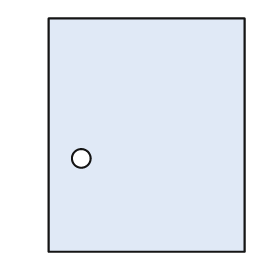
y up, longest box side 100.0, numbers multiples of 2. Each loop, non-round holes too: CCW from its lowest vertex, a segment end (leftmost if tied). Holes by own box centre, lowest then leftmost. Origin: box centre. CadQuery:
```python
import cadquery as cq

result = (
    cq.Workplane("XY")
    .moveTo(-42.0, -50.0)
    .lineTo(42.0, -50.0)
    .lineTo(42.0, 50.0)
    .lineTo(-42.0, 50.0)
    .close()
    .moveTo(-28.0, -10.0)
    .circle(4.0)
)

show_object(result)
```